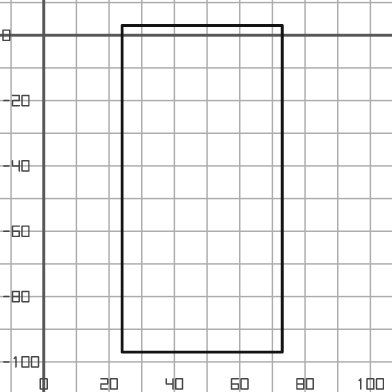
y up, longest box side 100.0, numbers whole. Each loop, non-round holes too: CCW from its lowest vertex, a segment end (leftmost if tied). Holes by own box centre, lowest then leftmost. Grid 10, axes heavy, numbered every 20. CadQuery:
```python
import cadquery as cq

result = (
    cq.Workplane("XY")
    .moveTo(24.0, -97.0)
    .lineTo(73.0, -97.0)
    .lineTo(73.0, 3.0)
    .lineTo(24.0, 3.0)
    .close()
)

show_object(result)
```